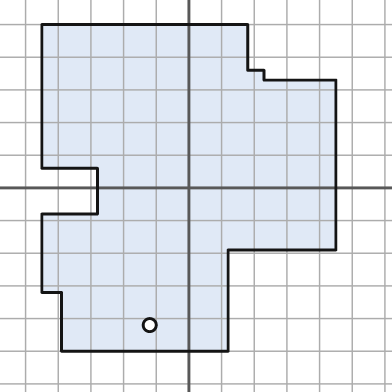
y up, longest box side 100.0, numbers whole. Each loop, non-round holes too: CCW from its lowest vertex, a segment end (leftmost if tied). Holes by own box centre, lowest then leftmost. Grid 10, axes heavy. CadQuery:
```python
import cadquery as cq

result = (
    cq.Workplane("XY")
    .moveTo(-39.0, -50.0)
    .lineTo(12.0, -50.0)
    .lineTo(12.0, -19.0)
    .lineTo(45.0, -19.0)
    .lineTo(45.0, 33.0)
    .lineTo(23.0, 33.0)
    .lineTo(23.0, 36.0)
    .lineTo(18.0, 36.0)
    .lineTo(18.0, 50.0)
    .lineTo(-45.0, 50.0)
    .lineTo(-45.0, 6.0)
    .lineTo(-28.0, 6.0)
    .lineTo(-28.0, -8.0)
    .lineTo(-45.0, -8.0)
    .lineTo(-45.0, -32.0)
    .lineTo(-39.0, -32.0)
    .close()
    .moveTo(-12.0, -42.0)
    .circle(2.0)
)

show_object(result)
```